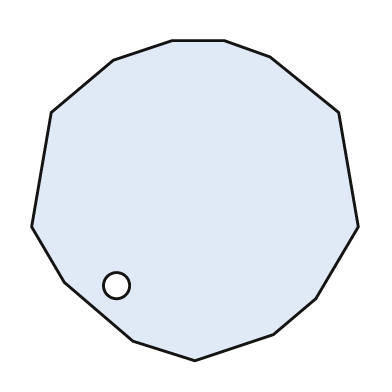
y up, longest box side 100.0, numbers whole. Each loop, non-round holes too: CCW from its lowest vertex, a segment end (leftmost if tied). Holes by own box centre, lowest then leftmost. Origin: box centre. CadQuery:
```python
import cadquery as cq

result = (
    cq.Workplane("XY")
    .moveTo(0.0, -49.0)
    .lineTo(24.0, -41.0)
    .lineTo(37.0, -30.0)
    .lineTo(50.0, -8.0)
    .lineTo(44.0, 27.0)
    .lineTo(23.0, 44.0)
    .lineTo(9.0, 49.0)
    .lineTo(-7.0, 49.0)
    .lineTo(-25.0, 43.0)
    .lineTo(-44.0, 27.0)
    .lineTo(-50.0, -8.0)
    .lineTo(-40.0, -25.0)
    .lineTo(-19.0, -43.0)
    .close()
    .moveTo(-24.0, -26.0)
    .circle(4.0)
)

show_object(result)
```